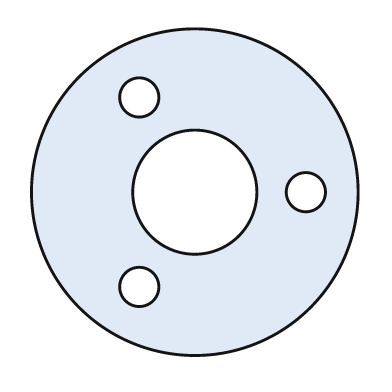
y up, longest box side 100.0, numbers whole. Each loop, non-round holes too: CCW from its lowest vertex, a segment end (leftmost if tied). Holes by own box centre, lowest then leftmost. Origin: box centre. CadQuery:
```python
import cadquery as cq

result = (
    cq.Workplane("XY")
    .moveTo(0.0, 0.0)
    .circle(50.0)
    .moveTo(-17.0, -29.0)
    .circle(6.0)
    .moveTo(0.0, 0.0)
    .circle(19.0)
    .moveTo(34.0, 0.0)
    .circle(6.0)
    .moveTo(-17.0, 29.0)
    .circle(6.0)
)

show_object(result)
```